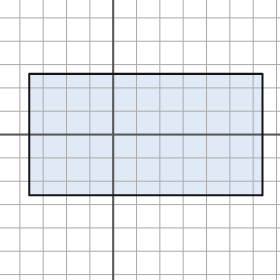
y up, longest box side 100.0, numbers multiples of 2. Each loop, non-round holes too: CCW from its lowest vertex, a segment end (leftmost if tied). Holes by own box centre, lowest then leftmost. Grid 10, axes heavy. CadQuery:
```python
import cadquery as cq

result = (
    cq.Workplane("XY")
    .moveTo(-36.0, -26.0)
    .lineTo(64.0, -26.0)
    .lineTo(64.0, 26.0)
    .lineTo(-36.0, 26.0)
    .close()
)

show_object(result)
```